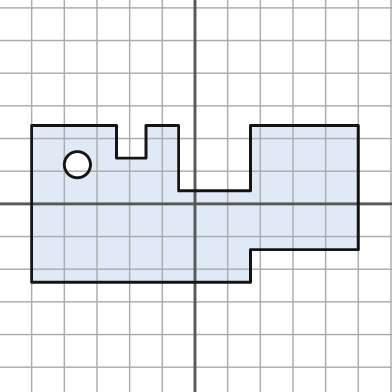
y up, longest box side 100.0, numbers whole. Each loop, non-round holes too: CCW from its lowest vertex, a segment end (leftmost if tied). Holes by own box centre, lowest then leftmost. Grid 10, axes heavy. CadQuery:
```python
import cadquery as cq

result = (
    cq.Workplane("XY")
    .moveTo(-50.0, -24.0)
    .lineTo(17.0, -24.0)
    .lineTo(17.0, -14.0)
    .lineTo(50.0, -14.0)
    .lineTo(50.0, 24.0)
    .lineTo(17.0, 24.0)
    .lineTo(17.0, 4.0)
    .lineTo(-5.0, 4.0)
    .lineTo(-5.0, 24.0)
    .lineTo(-15.0, 24.0)
    .lineTo(-15.0, 14.0)
    .lineTo(-24.0, 14.0)
    .lineTo(-24.0, 24.0)
    .lineTo(-50.0, 24.0)
    .close()
    .moveTo(-36.0, 12.0)
    .circle(4.0)
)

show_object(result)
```